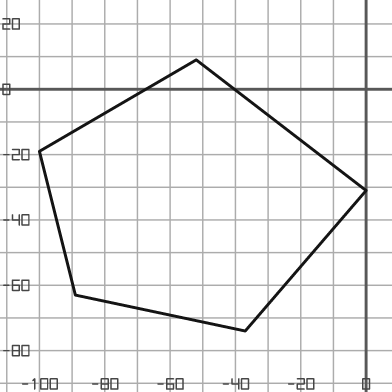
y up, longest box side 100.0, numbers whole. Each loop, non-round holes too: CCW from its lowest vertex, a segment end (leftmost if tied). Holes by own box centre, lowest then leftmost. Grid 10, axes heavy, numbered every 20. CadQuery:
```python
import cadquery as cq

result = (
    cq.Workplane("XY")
    .moveTo(-37.0, -74.0)
    .lineTo(0.0, -31.0)
    .lineTo(-52.0, 9.0)
    .lineTo(-100.0, -19.0)
    .lineTo(-89.0, -63.0)
    .close()
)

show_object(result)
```